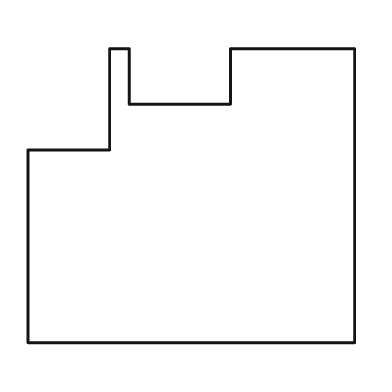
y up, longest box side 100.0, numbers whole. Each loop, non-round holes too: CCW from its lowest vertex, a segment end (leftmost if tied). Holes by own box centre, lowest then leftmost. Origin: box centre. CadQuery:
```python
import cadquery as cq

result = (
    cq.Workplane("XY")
    .moveTo(-50.0, -45.0)
    .lineTo(50.0, -45.0)
    .lineTo(50.0, 45.0)
    .lineTo(12.0, 45.0)
    .lineTo(12.0, 28.0)
    .lineTo(-19.0, 28.0)
    .lineTo(-19.0, 45.0)
    .lineTo(-25.0, 45.0)
    .lineTo(-25.0, 14.0)
    .lineTo(-50.0, 14.0)
    .close()
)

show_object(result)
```